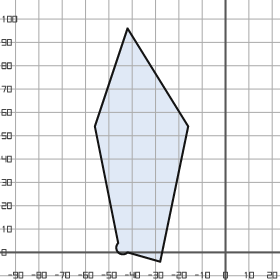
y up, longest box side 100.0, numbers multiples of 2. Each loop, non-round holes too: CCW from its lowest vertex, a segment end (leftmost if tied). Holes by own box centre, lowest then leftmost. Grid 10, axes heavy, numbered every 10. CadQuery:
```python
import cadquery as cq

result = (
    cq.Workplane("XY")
    .moveTo(-28.0, -4.0)
    .lineTo(-16.0, 54.0)
    .lineTo(-42.0, 96.0)
    .lineTo(-56.0, 54.0)
    .lineTo(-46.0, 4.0)
    .threePointArc((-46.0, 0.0), (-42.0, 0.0))
    .close()
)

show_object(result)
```